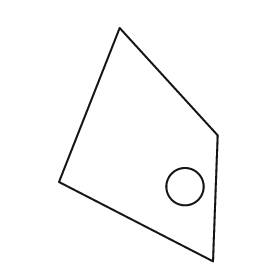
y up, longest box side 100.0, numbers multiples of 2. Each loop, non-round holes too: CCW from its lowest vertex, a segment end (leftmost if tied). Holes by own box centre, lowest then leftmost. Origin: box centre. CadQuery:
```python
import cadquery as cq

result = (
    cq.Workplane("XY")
    .moveTo(32.0, -50.0)
    .lineTo(34.0, 4.0)
    .lineTo(-8.0, 50.0)
    .lineTo(-34.0, -16.0)
    .close()
    .moveTo(20.0, -18.0)
    .circle(8.0)
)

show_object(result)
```